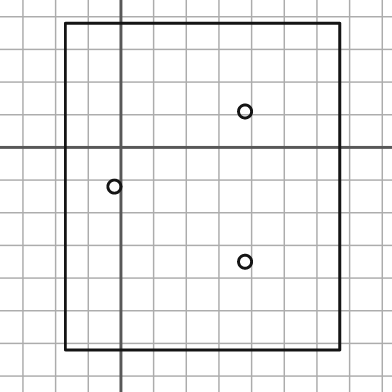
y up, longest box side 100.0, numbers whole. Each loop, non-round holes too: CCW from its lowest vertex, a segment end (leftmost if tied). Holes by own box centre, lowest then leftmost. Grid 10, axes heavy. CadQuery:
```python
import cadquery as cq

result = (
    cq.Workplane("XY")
    .moveTo(-17.0, -62.0)
    .lineTo(67.0, -62.0)
    .lineTo(67.0, 38.0)
    .lineTo(-17.0, 38.0)
    .close()
    .moveTo(38.0, -35.0)
    .circle(2.0)
    .moveTo(-2.0, -12.0)
    .circle(2.0)
    .moveTo(38.0, 11.0)
    .circle(2.0)
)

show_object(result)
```